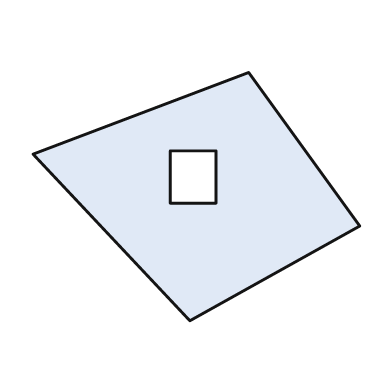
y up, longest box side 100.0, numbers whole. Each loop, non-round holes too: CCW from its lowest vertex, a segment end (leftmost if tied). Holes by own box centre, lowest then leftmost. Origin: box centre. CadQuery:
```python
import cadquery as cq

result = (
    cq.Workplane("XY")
    .moveTo(-2.0, -38.0)
    .lineTo(50.0, -9.0)
    .lineTo(16.0, 38.0)
    .lineTo(-50.0, 13.0)
    .close()
    .moveTo(-8.0, -2.0)
    .lineTo(6.0, -2.0)
    .lineTo(6.0, 14.0)
    .lineTo(-8.0, 14.0)
    .close()
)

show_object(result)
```